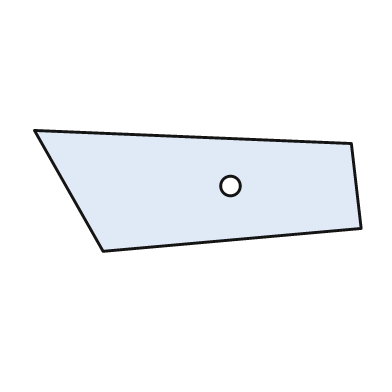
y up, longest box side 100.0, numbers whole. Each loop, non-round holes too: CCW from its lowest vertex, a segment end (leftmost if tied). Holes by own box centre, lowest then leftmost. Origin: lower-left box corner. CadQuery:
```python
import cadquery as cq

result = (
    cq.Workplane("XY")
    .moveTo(21.0, 0.0)
    .lineTo(100.0, 7.0)
    .lineTo(97.0, 33.0)
    .lineTo(0.0, 37.0)
    .close()
    .moveTo(60.0, 20.0)
    .circle(3.0)
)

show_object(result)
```